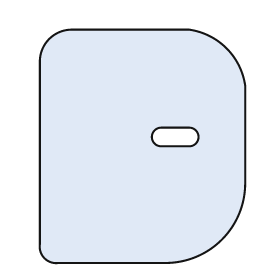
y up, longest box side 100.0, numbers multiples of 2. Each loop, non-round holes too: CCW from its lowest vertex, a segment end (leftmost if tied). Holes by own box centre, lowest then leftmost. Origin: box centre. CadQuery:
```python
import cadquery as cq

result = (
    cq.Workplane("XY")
    .moveTo(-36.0, -50.0)
    .lineTo(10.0, -50.0)
    .threePointArc((34.0, -40.0), (44.0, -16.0))
    .lineTo(44.0, 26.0)
    .threePointArc((36.0, 42.0), (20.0, 50.0))
    .lineTo(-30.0, 50.0)
    .threePointArc((-40.0, 46.0), (-44.0, 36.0))
    .lineTo(-44.0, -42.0)
    .threePointArc((-42.0, -48.0), (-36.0, -50.0))
    .close()
    .moveTo(8.0, 0.0)
    .lineTo(20.0, 0.0)
    .threePointArc((24.0, 4.0), (20.0, 8.0))
    .lineTo(8.0, 8.0)
    .threePointArc((4.0, 4.0), (8.0, 0.0))
    .close()
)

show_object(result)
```